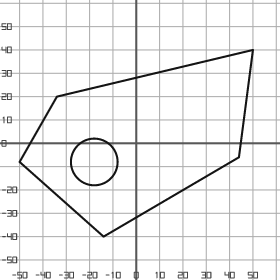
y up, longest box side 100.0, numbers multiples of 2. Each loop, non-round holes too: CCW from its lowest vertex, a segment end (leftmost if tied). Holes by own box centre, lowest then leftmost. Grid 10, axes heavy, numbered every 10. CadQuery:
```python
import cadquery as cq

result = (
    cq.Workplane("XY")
    .moveTo(-14.0, -40.0)
    .lineTo(44.0, -6.0)
    .lineTo(50.0, 40.0)
    .lineTo(-34.0, 20.0)
    .lineTo(-50.0, -8.0)
    .close()
    .moveTo(-18.0, -8.0)
    .circle(10.0)
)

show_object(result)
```